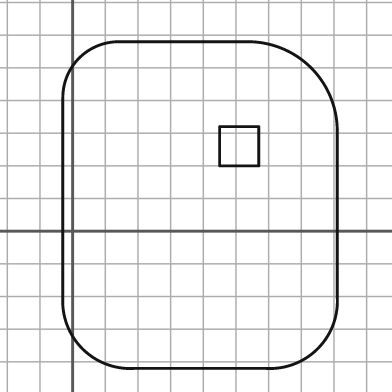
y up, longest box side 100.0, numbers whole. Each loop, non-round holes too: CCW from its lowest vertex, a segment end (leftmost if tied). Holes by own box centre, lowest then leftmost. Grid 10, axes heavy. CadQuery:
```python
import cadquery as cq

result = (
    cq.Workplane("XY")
    .moveTo(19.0, -42.0)
    .lineTo(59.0, -42.0)
    .threePointArc((75.0, -36.0), (81.0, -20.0))
    .lineTo(81.0, 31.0)
    .threePointArc((73.0, 50.0), (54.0, 58.0))
    .lineTo(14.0, 58.0)
    .threePointArc((2.0, 53.0), (-3.0, 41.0))
    .lineTo(-3.0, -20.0)
    .threePointArc((3.0, -36.0), (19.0, -42.0))
    .close()
    .moveTo(45.0, 20.0)
    .lineTo(57.0, 20.0)
    .lineTo(57.0, 32.0)
    .lineTo(45.0, 32.0)
    .close()
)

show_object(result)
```